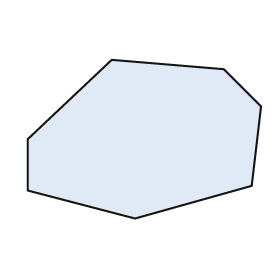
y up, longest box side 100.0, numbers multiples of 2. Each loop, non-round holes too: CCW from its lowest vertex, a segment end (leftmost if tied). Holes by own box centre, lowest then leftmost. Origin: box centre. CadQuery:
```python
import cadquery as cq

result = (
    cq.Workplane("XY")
    .moveTo(-4.0, -34.0)
    .lineTo(46.0, -20.0)
    .lineTo(50.0, 14.0)
    .lineTo(34.0, 30.0)
    .lineTo(-14.0, 34.0)
    .lineTo(-50.0, 0.0)
    .lineTo(-50.0, -22.0)
    .close()
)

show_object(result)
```